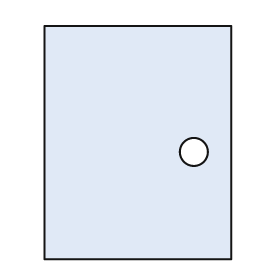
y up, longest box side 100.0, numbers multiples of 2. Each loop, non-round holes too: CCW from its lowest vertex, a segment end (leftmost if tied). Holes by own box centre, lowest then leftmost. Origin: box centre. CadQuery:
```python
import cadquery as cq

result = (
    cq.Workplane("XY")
    .moveTo(-40.0, -50.0)
    .lineTo(40.0, -50.0)
    .lineTo(40.0, 50.0)
    .lineTo(-40.0, 50.0)
    .close()
    .moveTo(24.0, -4.0)
    .circle(6.0)
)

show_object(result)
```